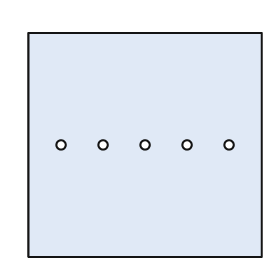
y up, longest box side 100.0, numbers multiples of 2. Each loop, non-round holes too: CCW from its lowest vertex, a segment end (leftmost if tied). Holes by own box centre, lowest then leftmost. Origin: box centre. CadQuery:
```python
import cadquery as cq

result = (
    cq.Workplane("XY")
    .moveTo(-50.0, -48.0)
    .lineTo(50.0, -48.0)
    .lineTo(50.0, 48.0)
    .lineTo(-50.0, 48.0)
    .close()
    .moveTo(-36.0, 0.0)
    .circle(2.0)
    .moveTo(-18.0, 0.0)
    .circle(2.0)
    .moveTo(0.0, 0.0)
    .circle(2.0)
    .moveTo(18.0, 0.0)
    .circle(2.0)
    .moveTo(36.0, 0.0)
    .circle(2.0)
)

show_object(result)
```